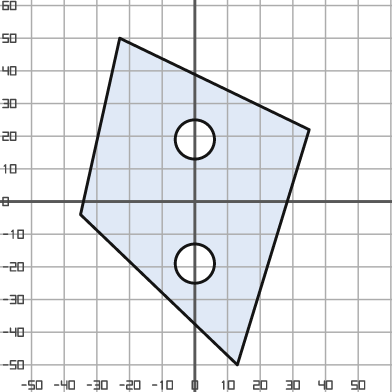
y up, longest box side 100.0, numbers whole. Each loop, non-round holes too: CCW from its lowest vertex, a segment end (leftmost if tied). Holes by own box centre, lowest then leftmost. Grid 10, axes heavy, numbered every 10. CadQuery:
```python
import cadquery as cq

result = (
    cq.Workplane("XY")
    .moveTo(13.0, -50.0)
    .lineTo(35.0, 22.0)
    .lineTo(-23.0, 50.0)
    .lineTo(-35.0, -4.0)
    .close()
    .moveTo(0.0, -19.0)
    .circle(6.0)
    .moveTo(0.0, 19.0)
    .circle(6.0)
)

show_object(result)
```